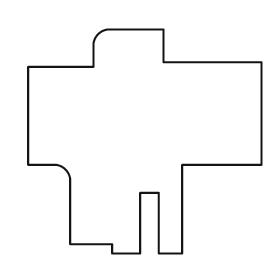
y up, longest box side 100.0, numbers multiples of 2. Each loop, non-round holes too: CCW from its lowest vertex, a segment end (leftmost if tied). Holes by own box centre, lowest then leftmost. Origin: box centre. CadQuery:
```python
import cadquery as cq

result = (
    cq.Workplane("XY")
    .moveTo(-14.0, -48.0)
    .lineTo(-2.0, -48.0)
    .lineTo(-2.0, -22.0)
    .lineTo(6.0, -22.0)
    .lineTo(6.0, -48.0)
    .lineTo(16.0, -48.0)
    .lineTo(16.0, -10.0)
    .lineTo(50.0, -10.0)
    .lineTo(50.0, 34.0)
    .lineTo(8.0, 34.0)
    .lineTo(8.0, 48.0)
    .lineTo(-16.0, 48.0)
    .threePointArc((-20.0, 46.0), (-22.0, 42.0))
    .lineTo(-22.0, 32.0)
    .lineTo(-50.0, 32.0)
    .lineTo(-50.0, -10.0)
    .lineTo(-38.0, -10.0)
    .threePointArc((-34.0, -12.0), (-32.0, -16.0))
    .lineTo(-32.0, -44.0)
    .lineTo(-14.0, -44.0)
    .close()
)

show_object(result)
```